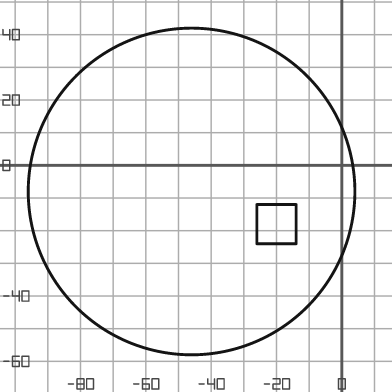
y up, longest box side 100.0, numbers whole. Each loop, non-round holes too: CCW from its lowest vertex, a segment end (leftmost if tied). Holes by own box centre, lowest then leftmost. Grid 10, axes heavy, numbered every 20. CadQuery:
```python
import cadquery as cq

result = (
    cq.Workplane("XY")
    .moveTo(-46.0, -8.0)
    .circle(50.0)
    .moveTo(-26.0, -24.0)
    .lineTo(-14.0, -24.0)
    .lineTo(-14.0, -12.0)
    .lineTo(-26.0, -12.0)
    .close()
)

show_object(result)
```